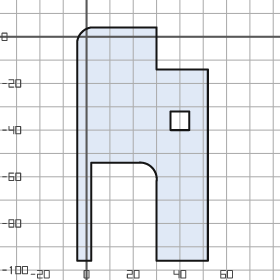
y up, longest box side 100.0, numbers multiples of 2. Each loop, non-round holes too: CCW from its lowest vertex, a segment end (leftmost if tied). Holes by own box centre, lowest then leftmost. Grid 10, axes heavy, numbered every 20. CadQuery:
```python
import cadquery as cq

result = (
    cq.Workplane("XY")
    .moveTo(-4.0, -96.0)
    .lineTo(2.0, -96.0)
    .lineTo(2.0, -54.0)
    .lineTo(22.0, -54.0)
    .threePointArc((28.0, -56.0), (30.0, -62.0))
    .lineTo(30.0, -96.0)
    .lineTo(52.0, -96.0)
    .lineTo(52.0, -14.0)
    .lineTo(30.0, -14.0)
    .lineTo(30.0, 4.0)
    .lineTo(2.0, 4.0)
    .threePointArc((-2.0, 2.0), (-4.0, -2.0))
    .close()
    .moveTo(36.0, -40.0)
    .lineTo(44.0, -40.0)
    .lineTo(44.0, -32.0)
    .lineTo(36.0, -32.0)
    .close()
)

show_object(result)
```